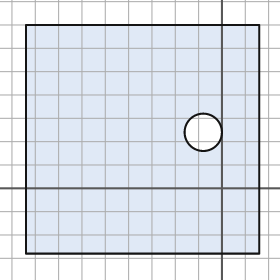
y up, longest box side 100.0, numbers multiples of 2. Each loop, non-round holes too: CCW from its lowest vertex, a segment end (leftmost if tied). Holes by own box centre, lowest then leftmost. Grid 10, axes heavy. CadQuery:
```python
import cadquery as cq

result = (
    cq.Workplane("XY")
    .moveTo(-84.0, -28.0)
    .lineTo(16.0, -28.0)
    .lineTo(16.0, 70.0)
    .lineTo(-84.0, 70.0)
    .close()
    .moveTo(-8.0, 24.0)
    .circle(8.0)
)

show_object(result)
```